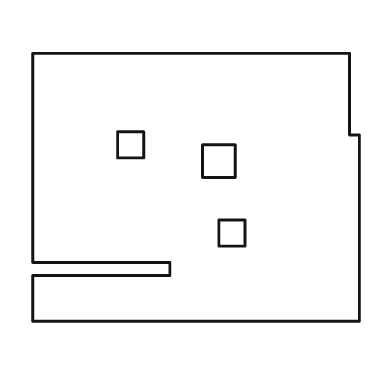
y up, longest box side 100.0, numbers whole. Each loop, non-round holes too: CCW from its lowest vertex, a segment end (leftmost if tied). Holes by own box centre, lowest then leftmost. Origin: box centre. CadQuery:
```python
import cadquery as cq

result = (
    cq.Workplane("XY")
    .moveTo(-50.0, -41.0)
    .lineTo(50.0, -41.0)
    .lineTo(50.0, 16.0)
    .lineTo(47.0, 16.0)
    .lineTo(47.0, 41.0)
    .lineTo(-50.0, 41.0)
    .lineTo(-50.0, -23.0)
    .lineTo(-8.0, -23.0)
    .lineTo(-8.0, -27.0)
    .lineTo(-50.0, -27.0)
    .close()
    .moveTo(7.0, -18.0)
    .lineTo(15.0, -18.0)
    .lineTo(15.0, -10.0)
    .lineTo(7.0, -10.0)
    .close()
    .moveTo(2.0, 3.0)
    .lineTo(12.0, 3.0)
    .lineTo(12.0, 13.0)
    .lineTo(2.0, 13.0)
    .close()
    .moveTo(-24.0, 9.0)
    .lineTo(-16.0, 9.0)
    .lineTo(-16.0, 17.0)
    .lineTo(-24.0, 17.0)
    .close()
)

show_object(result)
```